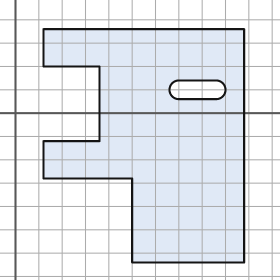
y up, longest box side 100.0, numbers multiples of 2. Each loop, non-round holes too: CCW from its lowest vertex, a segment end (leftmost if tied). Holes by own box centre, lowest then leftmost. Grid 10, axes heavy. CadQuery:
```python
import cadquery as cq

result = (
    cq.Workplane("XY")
    .moveTo(50.0, -64.0)
    .lineTo(98.0, -64.0)
    .lineTo(98.0, 36.0)
    .lineTo(12.0, 36.0)
    .lineTo(12.0, 20.0)
    .lineTo(36.0, 20.0)
    .lineTo(36.0, -12.0)
    .lineTo(12.0, -12.0)
    .lineTo(12.0, -28.0)
    .lineTo(50.0, -28.0)
    .close()
    .moveTo(70.0, 6.0)
    .lineTo(86.0, 6.0)
    .threePointArc((90.0, 10.0), (86.0, 14.0))
    .lineTo(70.0, 14.0)
    .threePointArc((66.0, 10.0), (70.0, 6.0))
    .close()
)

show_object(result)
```